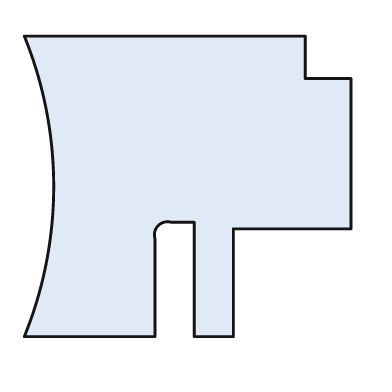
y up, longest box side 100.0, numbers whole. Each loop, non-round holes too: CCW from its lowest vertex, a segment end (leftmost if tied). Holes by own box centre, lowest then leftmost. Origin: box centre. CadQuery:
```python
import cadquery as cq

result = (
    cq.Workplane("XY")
    .moveTo(-50.0, -46.0)
    .lineTo(-10.0, -46.0)
    .lineTo(-10.0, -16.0)
    .threePointArc((-9.0, -12.0), (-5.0, -11.0))
    .lineTo(2.0, -11.0)
    .lineTo(2.0, -46.0)
    .lineTo(14.0, -46.0)
    .lineTo(14.0, -13.0)
    .lineTo(50.0, -13.0)
    .lineTo(50.0, 33.0)
    .lineTo(36.0, 33.0)
    .lineTo(36.0, 46.0)
    .lineTo(-50.0, 46.0)
    .threePointArc((-41.0, 0.0), (-50.0, -46.0))
    .close()
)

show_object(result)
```